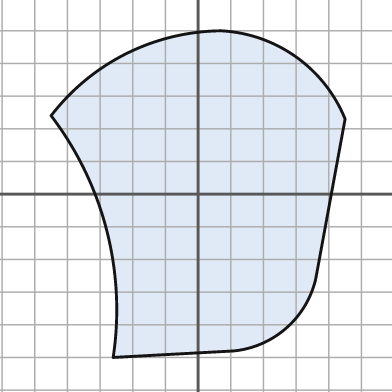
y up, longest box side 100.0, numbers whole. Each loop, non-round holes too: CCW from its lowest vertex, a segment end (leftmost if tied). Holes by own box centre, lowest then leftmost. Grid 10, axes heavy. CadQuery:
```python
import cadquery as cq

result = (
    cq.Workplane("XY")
    .moveTo(-26.0, -50.0)
    .lineTo(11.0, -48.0)
    .threePointArc((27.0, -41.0), (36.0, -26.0))
    .lineTo(45.0, 23.0)
    .threePointArc((30.0, 42.0), (7.0, 50.0))
    .threePointArc((-22.0, 43.0), (-45.0, 24.0))
    .threePointArc((-28.0, -11.0), (-26.0, -50.0))
    .close()
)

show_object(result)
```